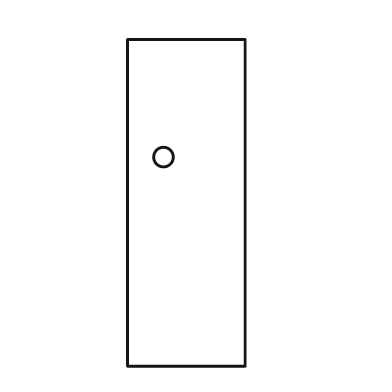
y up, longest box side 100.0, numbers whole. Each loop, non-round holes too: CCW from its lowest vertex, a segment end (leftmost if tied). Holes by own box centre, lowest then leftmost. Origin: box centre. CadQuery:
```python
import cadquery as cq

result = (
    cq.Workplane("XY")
    .moveTo(-18.0, -50.0)
    .lineTo(18.0, -50.0)
    .lineTo(18.0, 50.0)
    .lineTo(-18.0, 50.0)
    .close()
    .moveTo(-7.0, 14.0)
    .circle(3.0)
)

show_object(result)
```